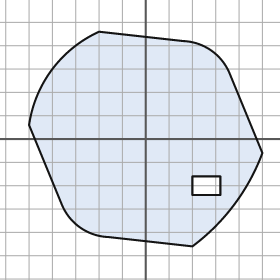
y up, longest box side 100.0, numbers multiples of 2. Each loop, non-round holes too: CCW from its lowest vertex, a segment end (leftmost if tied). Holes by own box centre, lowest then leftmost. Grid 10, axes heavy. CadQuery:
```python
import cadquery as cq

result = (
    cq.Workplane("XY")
    .moveTo(20.0, -46.0)
    .threePointArc((38.0, -28.0), (50.0, -6.0))
    .lineTo(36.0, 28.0)
    .threePointArc((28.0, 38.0), (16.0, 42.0))
    .lineTo(-20.0, 46.0)
    .threePointArc((-40.0, 30.0), (-50.0, 6.0))
    .lineTo(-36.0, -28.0)
    .threePointArc((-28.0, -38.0), (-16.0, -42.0))
    .close()
    .moveTo(20.0, -24.0)
    .lineTo(32.0, -24.0)
    .lineTo(32.0, -16.0)
    .lineTo(20.0, -16.0)
    .close()
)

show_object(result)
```